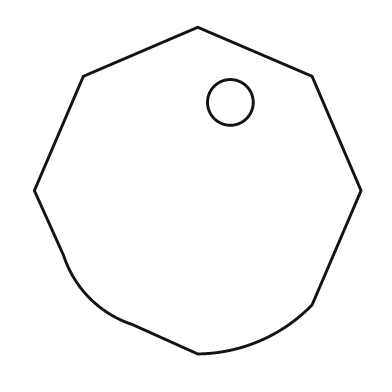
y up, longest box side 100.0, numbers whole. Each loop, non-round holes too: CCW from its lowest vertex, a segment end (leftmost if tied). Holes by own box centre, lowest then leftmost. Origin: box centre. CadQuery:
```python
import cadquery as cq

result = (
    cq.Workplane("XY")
    .moveTo(0.0, -50.0)
    .threePointArc((19.0, -46.0), (35.0, -35.0))
    .lineTo(50.0, 0.0)
    .lineTo(35.0, 35.0)
    .lineTo(0.0, 50.0)
    .lineTo(-35.0, 35.0)
    .lineTo(-50.0, 0.0)
    .lineTo(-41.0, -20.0)
    .threePointArc((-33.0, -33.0), (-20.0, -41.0))
    .close()
    .moveTo(10.0, 27.0)
    .circle(7.0)
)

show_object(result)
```